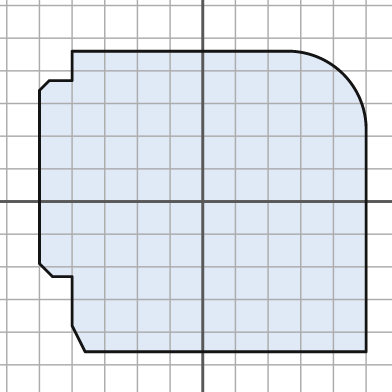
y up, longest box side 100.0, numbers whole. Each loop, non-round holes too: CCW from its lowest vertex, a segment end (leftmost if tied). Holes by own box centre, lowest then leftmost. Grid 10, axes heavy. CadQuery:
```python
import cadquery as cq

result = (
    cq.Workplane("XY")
    .moveTo(-36.0, -46.0)
    .lineTo(50.0, -46.0)
    .lineTo(50.0, 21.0)
    .threePointArc((43.0, 39.0), (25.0, 46.0))
    .lineTo(-40.0, 46.0)
    .lineTo(-40.0, 37.0)
    .lineTo(-47.0, 37.0)
    .lineTo(-50.0, 34.0)
    .lineTo(-50.0, -19.0)
    .lineTo(-46.0, -23.0)
    .lineTo(-40.0, -23.0)
    .lineTo(-40.0, -38.0)
    .close()
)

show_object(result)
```